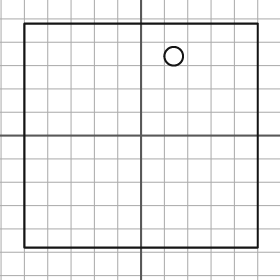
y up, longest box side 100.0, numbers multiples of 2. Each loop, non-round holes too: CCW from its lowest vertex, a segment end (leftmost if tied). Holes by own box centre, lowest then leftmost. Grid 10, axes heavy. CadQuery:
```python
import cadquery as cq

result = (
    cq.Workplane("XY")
    .moveTo(-50.0, -48.0)
    .lineTo(50.0, -48.0)
    .lineTo(50.0, 48.0)
    .lineTo(-50.0, 48.0)
    .close()
    .moveTo(14.0, 34.0)
    .circle(4.0)
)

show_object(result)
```